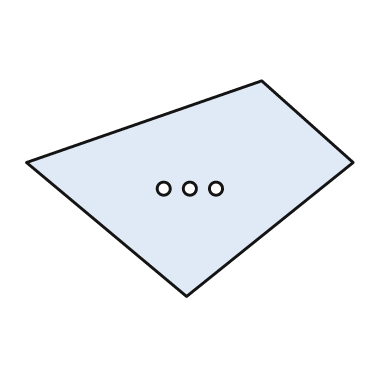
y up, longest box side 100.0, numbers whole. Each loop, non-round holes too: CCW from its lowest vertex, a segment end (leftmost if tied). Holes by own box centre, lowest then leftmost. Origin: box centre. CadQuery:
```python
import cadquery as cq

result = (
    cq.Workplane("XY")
    .moveTo(-1.0, -33.0)
    .lineTo(50.0, 8.0)
    .lineTo(22.0, 33.0)
    .lineTo(-50.0, 8.0)
    .close()
    .moveTo(-8.0, 0.0)
    .circle(2.0)
    .moveTo(0.0, 0.0)
    .circle(2.0)
    .moveTo(8.0, 0.0)
    .circle(2.0)
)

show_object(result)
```